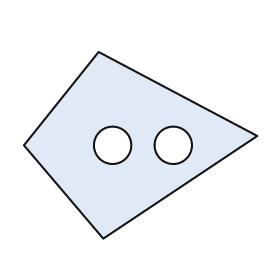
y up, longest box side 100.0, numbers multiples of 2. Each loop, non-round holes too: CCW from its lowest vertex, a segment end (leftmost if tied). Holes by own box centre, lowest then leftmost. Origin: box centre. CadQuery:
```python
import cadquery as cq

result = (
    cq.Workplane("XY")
    .moveTo(-16.0, -40.0)
    .lineTo(50.0, 4.0)
    .lineTo(-18.0, 40.0)
    .lineTo(-50.0, 0.0)
    .close()
    .moveTo(-12.0, 0.0)
    .circle(8.0)
    .moveTo(14.0, 0.0)
    .circle(8.0)
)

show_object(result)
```